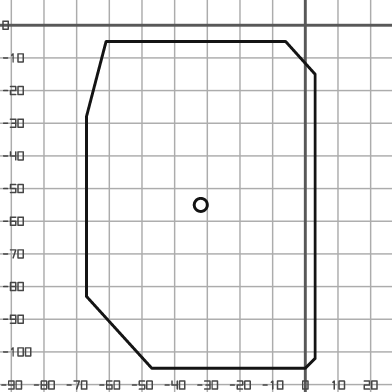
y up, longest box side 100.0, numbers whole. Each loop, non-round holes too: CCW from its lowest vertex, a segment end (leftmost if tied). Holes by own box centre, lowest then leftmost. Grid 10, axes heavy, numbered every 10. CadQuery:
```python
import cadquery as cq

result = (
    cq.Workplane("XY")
    .moveTo(-47.0, -105.0)
    .lineTo(0.0, -105.0)
    .lineTo(3.0, -102.0)
    .lineTo(3.0, -15.0)
    .lineTo(-6.0, -5.0)
    .lineTo(-61.0, -5.0)
    .lineTo(-67.0, -28.0)
    .lineTo(-67.0, -83.0)
    .close()
    .moveTo(-32.0, -55.0)
    .circle(2.0)
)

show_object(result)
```